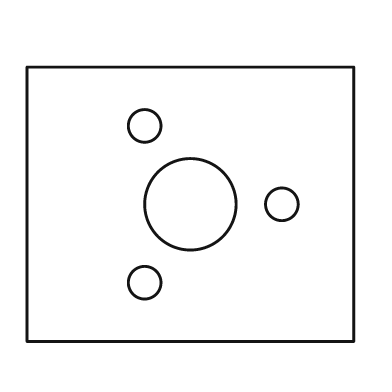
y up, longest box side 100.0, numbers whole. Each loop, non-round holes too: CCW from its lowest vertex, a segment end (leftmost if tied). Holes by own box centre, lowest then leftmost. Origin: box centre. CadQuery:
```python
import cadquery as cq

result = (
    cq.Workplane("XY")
    .moveTo(-50.0, -42.0)
    .lineTo(50.0, -42.0)
    .lineTo(50.0, 42.0)
    .lineTo(-50.0, 42.0)
    .close()
    .moveTo(-14.0, -24.0)
    .circle(5.0)
    .moveTo(0.0, 0.0)
    .circle(14.0)
    .moveTo(28.0, 0.0)
    .circle(5.0)
    .moveTo(-14.0, 24.0)
    .circle(5.0)
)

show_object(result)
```